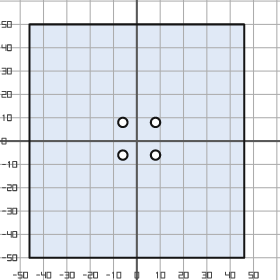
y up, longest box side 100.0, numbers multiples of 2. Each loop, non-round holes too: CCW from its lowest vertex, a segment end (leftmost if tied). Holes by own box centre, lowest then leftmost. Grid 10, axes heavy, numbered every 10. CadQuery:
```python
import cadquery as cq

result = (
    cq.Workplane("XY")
    .moveTo(-46.0, -50.0)
    .lineTo(46.0, -50.0)
    .lineTo(46.0, 50.0)
    .lineTo(-46.0, 50.0)
    .close()
    .moveTo(-6.0, -6.0)
    .circle(2.0)
    .moveTo(8.0, -6.0)
    .circle(2.0)
    .moveTo(-6.0, 8.0)
    .circle(2.0)
    .moveTo(8.0, 8.0)
    .circle(2.0)
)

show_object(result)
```